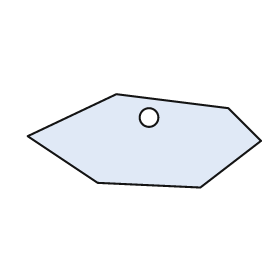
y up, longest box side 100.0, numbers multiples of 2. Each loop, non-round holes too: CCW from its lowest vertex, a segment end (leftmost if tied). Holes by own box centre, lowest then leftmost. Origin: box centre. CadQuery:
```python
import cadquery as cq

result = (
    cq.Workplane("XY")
    .moveTo(24.0, -20.0)
    .lineTo(50.0, 0.0)
    .lineTo(36.0, 14.0)
    .lineTo(-12.0, 20.0)
    .lineTo(-50.0, 2.0)
    .lineTo(-20.0, -18.0)
    .close()
    .moveTo(2.0, 10.0)
    .circle(4.0)
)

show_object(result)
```